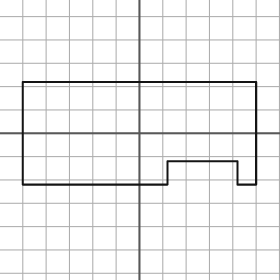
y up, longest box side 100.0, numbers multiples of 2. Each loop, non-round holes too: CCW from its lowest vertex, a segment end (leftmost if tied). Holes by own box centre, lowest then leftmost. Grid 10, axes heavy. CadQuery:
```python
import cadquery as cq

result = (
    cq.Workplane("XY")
    .moveTo(-50.0, -22.0)
    .lineTo(12.0, -22.0)
    .lineTo(12.0, -12.0)
    .lineTo(42.0, -12.0)
    .lineTo(42.0, -22.0)
    .lineTo(50.0, -22.0)
    .lineTo(50.0, 22.0)
    .lineTo(-50.0, 22.0)
    .close()
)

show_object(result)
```